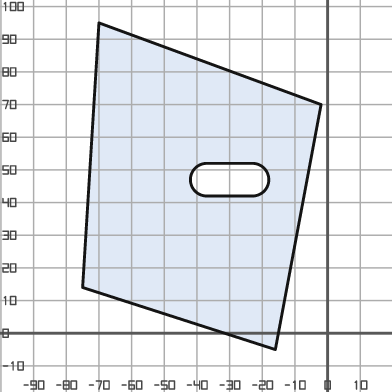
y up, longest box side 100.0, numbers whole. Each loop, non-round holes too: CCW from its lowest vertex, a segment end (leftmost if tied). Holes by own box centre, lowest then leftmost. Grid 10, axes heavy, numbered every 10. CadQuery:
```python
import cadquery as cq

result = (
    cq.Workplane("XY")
    .moveTo(-16.0, -5.0)
    .lineTo(-2.0, 70.0)
    .lineTo(-70.0, 95.0)
    .lineTo(-75.0, 14.0)
    .close()
    .moveTo(-37.0, 42.0)
    .lineTo(-23.0, 42.0)
    .threePointArc((-18.0, 47.0), (-23.0, 52.0))
    .lineTo(-37.0, 52.0)
    .threePointArc((-42.0, 47.0), (-37.0, 42.0))
    .close()
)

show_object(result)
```